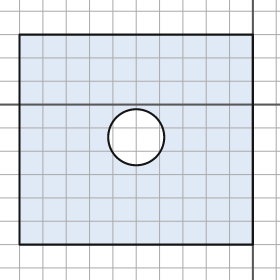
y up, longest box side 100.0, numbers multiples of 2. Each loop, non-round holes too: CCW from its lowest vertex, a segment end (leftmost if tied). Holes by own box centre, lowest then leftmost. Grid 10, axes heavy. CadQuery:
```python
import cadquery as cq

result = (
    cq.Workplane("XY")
    .moveTo(-100.0, -60.0)
    .lineTo(0.0, -60.0)
    .lineTo(0.0, 30.0)
    .lineTo(-100.0, 30.0)
    .close()
    .moveTo(-50.0, -14.0)
    .circle(12.0)
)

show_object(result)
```